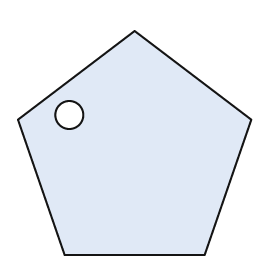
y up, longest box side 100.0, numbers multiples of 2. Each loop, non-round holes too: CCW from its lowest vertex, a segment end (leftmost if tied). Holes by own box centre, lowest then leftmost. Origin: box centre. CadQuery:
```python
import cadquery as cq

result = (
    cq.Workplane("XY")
    .moveTo(-30.0, -48.0)
    .lineTo(30.0, -48.0)
    .lineTo(50.0, 10.0)
    .lineTo(0.0, 48.0)
    .lineTo(-50.0, 10.0)
    .close()
    .moveTo(-28.0, 12.0)
    .circle(6.0)
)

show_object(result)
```